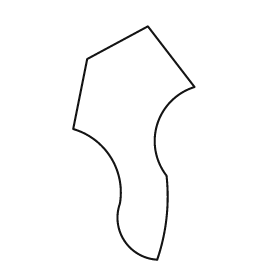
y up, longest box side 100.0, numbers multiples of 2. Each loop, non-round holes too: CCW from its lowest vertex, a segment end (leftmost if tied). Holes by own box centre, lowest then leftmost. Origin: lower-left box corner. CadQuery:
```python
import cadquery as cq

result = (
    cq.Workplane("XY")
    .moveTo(36.0, 0.0)
    .threePointArc((40.0, 18.0), (40.0, 36.0))
    .threePointArc((36.0, 58.0), (52.0, 74.0))
    .lineTo(32.0, 100.0)
    .lineTo(6.0, 86.0)
    .lineTo(0.0, 56.0)
    .threePointArc((16.0, 44.0), (20.0, 24.0))
    .threePointArc((22.0, 8.0), (36.0, 0.0))
    .close()
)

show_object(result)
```